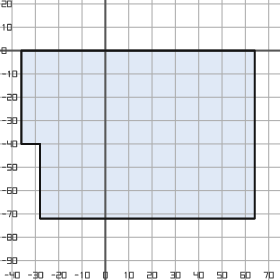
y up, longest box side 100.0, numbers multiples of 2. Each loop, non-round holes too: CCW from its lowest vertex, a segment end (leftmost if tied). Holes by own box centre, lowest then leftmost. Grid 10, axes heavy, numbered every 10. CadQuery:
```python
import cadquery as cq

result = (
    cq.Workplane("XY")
    .moveTo(-28.0, -72.0)
    .lineTo(64.0, -72.0)
    .lineTo(64.0, 0.0)
    .lineTo(-36.0, 0.0)
    .lineTo(-36.0, -40.0)
    .lineTo(-28.0, -40.0)
    .close()
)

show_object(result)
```